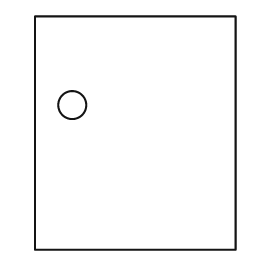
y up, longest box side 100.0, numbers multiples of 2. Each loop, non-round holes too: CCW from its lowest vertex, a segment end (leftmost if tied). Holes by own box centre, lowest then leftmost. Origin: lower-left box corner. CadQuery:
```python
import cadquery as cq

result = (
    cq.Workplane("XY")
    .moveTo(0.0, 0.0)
    .lineTo(86.0, 0.0)
    .lineTo(86.0, 100.0)
    .lineTo(0.0, 100.0)
    .close()
    .moveTo(16.0, 62.0)
    .circle(6.0)
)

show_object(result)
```